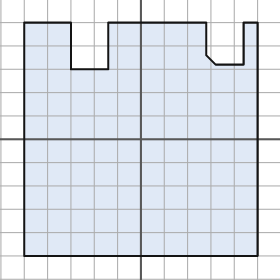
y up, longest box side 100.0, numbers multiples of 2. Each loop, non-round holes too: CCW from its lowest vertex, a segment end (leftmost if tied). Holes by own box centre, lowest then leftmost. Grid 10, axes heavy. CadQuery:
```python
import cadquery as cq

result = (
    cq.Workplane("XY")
    .moveTo(-50.0, -50.0)
    .lineTo(50.0, -50.0)
    .lineTo(50.0, 50.0)
    .lineTo(44.0, 50.0)
    .lineTo(44.0, 32.0)
    .lineTo(32.0, 32.0)
    .lineTo(28.0, 36.0)
    .lineTo(28.0, 50.0)
    .lineTo(-14.0, 50.0)
    .lineTo(-14.0, 30.0)
    .lineTo(-30.0, 30.0)
    .lineTo(-30.0, 50.0)
    .lineTo(-50.0, 50.0)
    .close()
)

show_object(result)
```